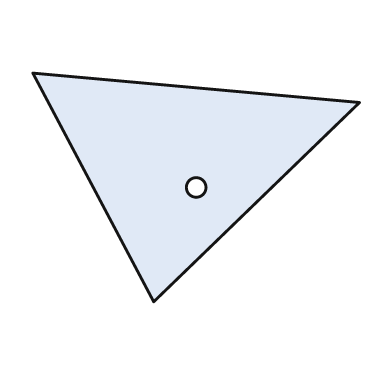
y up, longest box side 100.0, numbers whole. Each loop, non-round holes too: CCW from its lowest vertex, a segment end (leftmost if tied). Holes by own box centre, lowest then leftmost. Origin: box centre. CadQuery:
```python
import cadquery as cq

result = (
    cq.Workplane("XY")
    .moveTo(-13.0, -35.0)
    .lineTo(50.0, 26.0)
    .lineTo(-50.0, 35.0)
    .close()
    .moveTo(0.0, 0.0)
    .circle(3.0)
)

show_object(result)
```